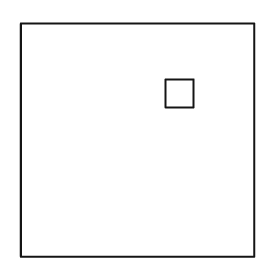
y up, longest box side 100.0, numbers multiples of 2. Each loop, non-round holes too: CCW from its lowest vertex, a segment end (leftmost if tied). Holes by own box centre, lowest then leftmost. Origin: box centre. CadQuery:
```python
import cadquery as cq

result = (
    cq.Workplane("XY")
    .moveTo(-50.0, -50.0)
    .lineTo(50.0, -50.0)
    .lineTo(50.0, 50.0)
    .lineTo(-50.0, 50.0)
    .close()
    .moveTo(12.0, 14.0)
    .lineTo(24.0, 14.0)
    .lineTo(24.0, 26.0)
    .lineTo(12.0, 26.0)
    .close()
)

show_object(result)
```